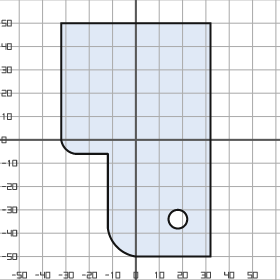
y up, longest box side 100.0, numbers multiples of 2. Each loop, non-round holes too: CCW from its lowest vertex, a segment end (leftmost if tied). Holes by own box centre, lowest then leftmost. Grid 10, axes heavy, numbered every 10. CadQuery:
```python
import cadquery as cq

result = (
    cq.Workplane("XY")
    .moveTo(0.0, -50.0)
    .lineTo(32.0, -50.0)
    .lineTo(32.0, 50.0)
    .lineTo(-32.0, 50.0)
    .lineTo(-32.0, 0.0)
    .threePointArc((-30.0, -4.0), (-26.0, -6.0))
    .lineTo(-12.0, -6.0)
    .lineTo(-12.0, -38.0)
    .threePointArc((-8.0, -46.0), (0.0, -50.0))
    .close()
    .moveTo(18.0, -34.0)
    .circle(4.0)
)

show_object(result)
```